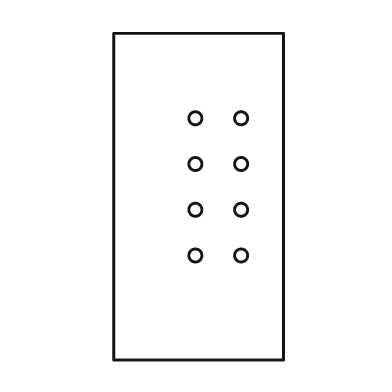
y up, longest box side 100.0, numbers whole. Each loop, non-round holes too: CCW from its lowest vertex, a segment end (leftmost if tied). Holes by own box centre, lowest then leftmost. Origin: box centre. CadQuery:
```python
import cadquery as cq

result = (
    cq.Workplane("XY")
    .moveTo(-26.0, -50.0)
    .lineTo(26.0, -50.0)
    .lineTo(26.0, 50.0)
    .lineTo(-26.0, 50.0)
    .close()
    .moveTo(-1.0, -18.0)
    .circle(2.0)
    .moveTo(13.0, -18.0)
    .circle(2.0)
    .moveTo(-1.0, -4.0)
    .circle(2.0)
    .moveTo(13.0, -4.0)
    .circle(2.0)
    .moveTo(-1.0, 10.0)
    .circle(2.0)
    .moveTo(13.0, 10.0)
    .circle(2.0)
    .moveTo(-1.0, 24.0)
    .circle(2.0)
    .moveTo(13.0, 24.0)
    .circle(2.0)
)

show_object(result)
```